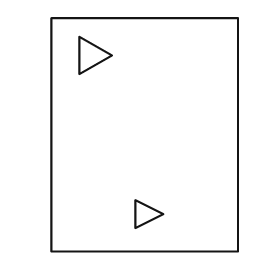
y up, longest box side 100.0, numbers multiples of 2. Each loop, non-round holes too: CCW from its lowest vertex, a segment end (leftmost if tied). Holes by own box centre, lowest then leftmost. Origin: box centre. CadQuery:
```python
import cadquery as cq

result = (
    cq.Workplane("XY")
    .moveTo(-40.0, -50.0)
    .lineTo(40.0, -50.0)
    .lineTo(40.0, 50.0)
    .lineTo(-40.0, 50.0)
    .close()
    .moveTo(-4.0, -40.0)
    .lineTo(8.0, -34.0)
    .lineTo(-4.0, -28.0)
    .close()
    .moveTo(-28.0, 26.0)
    .lineTo(-14.0, 34.0)
    .lineTo(-28.0, 42.0)
    .close()
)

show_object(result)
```